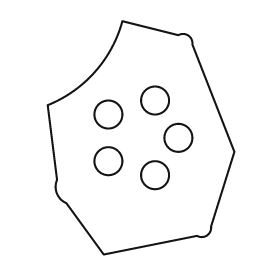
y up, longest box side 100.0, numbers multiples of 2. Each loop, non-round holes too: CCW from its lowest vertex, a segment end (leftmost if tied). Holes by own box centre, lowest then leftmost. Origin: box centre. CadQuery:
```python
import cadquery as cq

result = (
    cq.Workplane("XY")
    .moveTo(-16.0, -50.0)
    .lineTo(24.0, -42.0)
    .threePointArc((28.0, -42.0), (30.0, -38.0))
    .lineTo(40.0, -6.0)
    .lineTo(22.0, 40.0)
    .threePointArc((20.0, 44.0), (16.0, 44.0))
    .lineTo(-8.0, 50.0)
    .threePointArc((-20.0, 28.0), (-40.0, 14.0))
    .lineTo(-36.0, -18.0)
    .threePointArc((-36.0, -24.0), (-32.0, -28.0))
    .close()
    .moveTo(6.0, -16.0)
    .circle(6.0)
    .moveTo(-14.0, -10.0)
    .circle(6.0)
    .moveTo(16.0, 0.0)
    .circle(6.0)
    .moveTo(-14.0, 10.0)
    .circle(6.0)
    .moveTo(6.0, 16.0)
    .circle(6.0)
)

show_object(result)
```